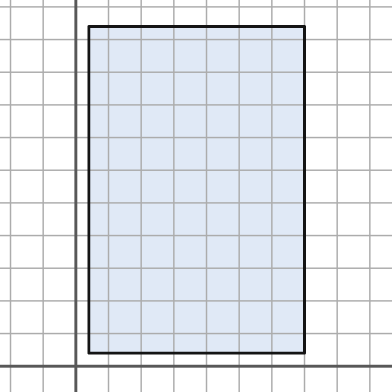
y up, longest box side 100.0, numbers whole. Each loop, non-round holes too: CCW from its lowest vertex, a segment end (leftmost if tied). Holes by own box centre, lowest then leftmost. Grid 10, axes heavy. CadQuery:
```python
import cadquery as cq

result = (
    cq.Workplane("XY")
    .moveTo(4.0, 4.0)
    .lineTo(70.0, 4.0)
    .lineTo(70.0, 104.0)
    .lineTo(4.0, 104.0)
    .close()
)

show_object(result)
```